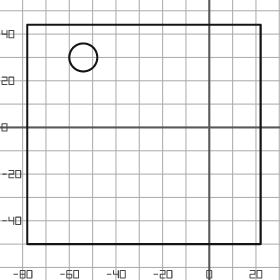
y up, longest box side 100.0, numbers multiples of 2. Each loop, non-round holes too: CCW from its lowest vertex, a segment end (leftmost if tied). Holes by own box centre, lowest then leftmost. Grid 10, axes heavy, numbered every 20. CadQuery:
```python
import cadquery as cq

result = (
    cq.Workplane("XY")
    .moveTo(-78.0, -50.0)
    .lineTo(22.0, -50.0)
    .lineTo(22.0, 44.0)
    .lineTo(-78.0, 44.0)
    .close()
    .moveTo(-54.0, 30.0)
    .circle(6.0)
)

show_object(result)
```